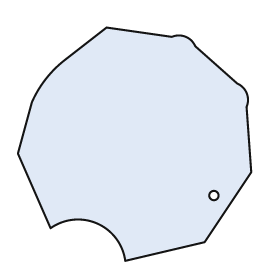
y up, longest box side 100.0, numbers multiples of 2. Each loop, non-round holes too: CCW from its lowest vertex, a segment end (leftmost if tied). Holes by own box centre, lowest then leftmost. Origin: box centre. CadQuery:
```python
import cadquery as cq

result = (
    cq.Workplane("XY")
    .moveTo(-4.0, -50.0)
    .lineTo(30.0, -42.0)
    .lineTo(50.0, -12.0)
    .lineTo(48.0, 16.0)
    .threePointArc((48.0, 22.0), (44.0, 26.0))
    .lineTo(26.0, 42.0)
    .threePointArc((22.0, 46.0), (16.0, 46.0))
    .lineTo(-12.0, 50.0)
    .lineTo(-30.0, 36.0)
    .threePointArc((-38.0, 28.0), (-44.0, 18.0))
    .lineTo(-50.0, -4.0)
    .lineTo(-36.0, -36.0)
    .threePointArc((-16.0, -34.0), (-4.0, -50.0))
    .close()
    .moveTo(34.0, -22.0)
    .circle(2.0)
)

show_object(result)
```